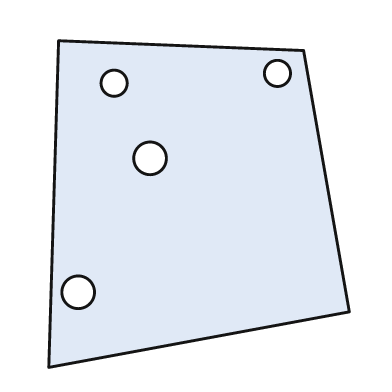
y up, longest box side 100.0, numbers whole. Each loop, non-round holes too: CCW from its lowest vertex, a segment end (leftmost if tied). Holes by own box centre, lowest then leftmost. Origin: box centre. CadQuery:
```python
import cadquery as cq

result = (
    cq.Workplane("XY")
    .moveTo(-46.0, -50.0)
    .lineTo(46.0, -33.0)
    .lineTo(32.0, 47.0)
    .lineTo(-43.0, 50.0)
    .close()
    .moveTo(-37.0, -27.0)
    .circle(5.0)
    .moveTo(-15.0, 14.0)
    .circle(5.0)
    .moveTo(-26.0, 37.0)
    .circle(4.0)
    .moveTo(24.0, 40.0)
    .circle(4.0)
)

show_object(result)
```